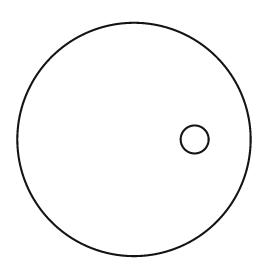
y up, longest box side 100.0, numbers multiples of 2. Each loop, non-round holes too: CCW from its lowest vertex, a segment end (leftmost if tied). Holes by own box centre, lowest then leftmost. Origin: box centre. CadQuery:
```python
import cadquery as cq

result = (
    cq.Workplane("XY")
    .moveTo(0.0, 0.0)
    .circle(50.0)
    .moveTo(26.0, 0.0)
    .circle(6.0)
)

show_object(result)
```